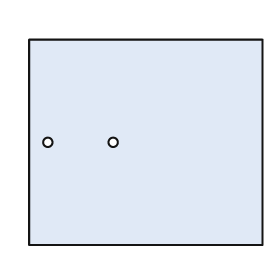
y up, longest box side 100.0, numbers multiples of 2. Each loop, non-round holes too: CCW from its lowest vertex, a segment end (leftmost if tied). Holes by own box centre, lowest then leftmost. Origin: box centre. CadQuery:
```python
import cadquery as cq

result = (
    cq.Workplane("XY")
    .moveTo(-50.0, -44.0)
    .lineTo(50.0, -44.0)
    .lineTo(50.0, 44.0)
    .lineTo(-50.0, 44.0)
    .close()
    .moveTo(-42.0, 0.0)
    .circle(2.0)
    .moveTo(-14.0, 0.0)
    .circle(2.0)
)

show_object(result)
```